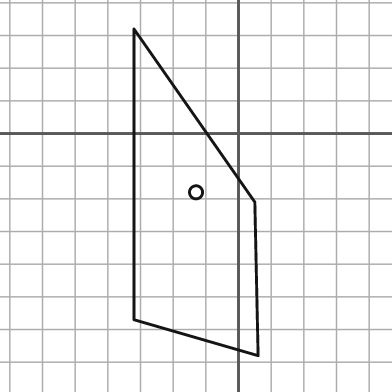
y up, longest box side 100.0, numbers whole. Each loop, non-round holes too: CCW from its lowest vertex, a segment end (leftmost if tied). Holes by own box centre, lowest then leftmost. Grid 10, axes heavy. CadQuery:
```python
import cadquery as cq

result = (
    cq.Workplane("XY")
    .moveTo(6.0, -68.0)
    .lineTo(5.0, -21.0)
    .lineTo(-32.0, 32.0)
    .lineTo(-32.0, -57.0)
    .close()
    .moveTo(-13.0, -18.0)
    .circle(2.0)
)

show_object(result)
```